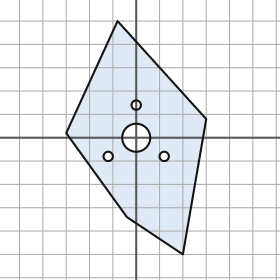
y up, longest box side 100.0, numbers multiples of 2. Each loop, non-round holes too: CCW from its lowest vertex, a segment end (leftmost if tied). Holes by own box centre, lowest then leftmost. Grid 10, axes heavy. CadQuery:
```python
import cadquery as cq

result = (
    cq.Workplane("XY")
    .moveTo(20.0, -50.0)
    .lineTo(30.0, 8.0)
    .lineTo(-8.0, 50.0)
    .lineTo(-30.0, 2.0)
    .lineTo(-4.0, -34.0)
    .close()
    .moveTo(-12.0, -8.0)
    .circle(2.0)
    .moveTo(12.0, -8.0)
    .circle(2.0)
    .moveTo(0.0, 0.0)
    .circle(6.0)
    .moveTo(0.0, 14.0)
    .circle(2.0)
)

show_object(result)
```